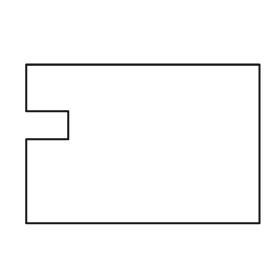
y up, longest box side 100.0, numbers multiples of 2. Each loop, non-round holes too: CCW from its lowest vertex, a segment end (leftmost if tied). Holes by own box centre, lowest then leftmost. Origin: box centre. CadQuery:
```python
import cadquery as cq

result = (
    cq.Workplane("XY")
    .moveTo(-50.0, -34.0)
    .lineTo(50.0, -34.0)
    .lineTo(50.0, 34.0)
    .lineTo(-50.0, 34.0)
    .lineTo(-50.0, 14.0)
    .lineTo(-32.0, 14.0)
    .lineTo(-32.0, 2.0)
    .lineTo(-50.0, 2.0)
    .close()
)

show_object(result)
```